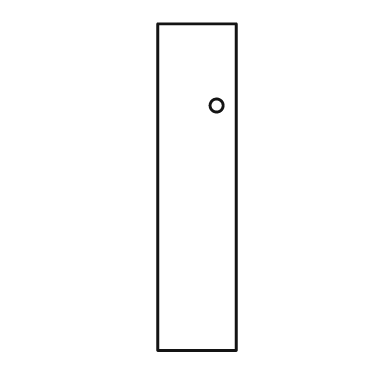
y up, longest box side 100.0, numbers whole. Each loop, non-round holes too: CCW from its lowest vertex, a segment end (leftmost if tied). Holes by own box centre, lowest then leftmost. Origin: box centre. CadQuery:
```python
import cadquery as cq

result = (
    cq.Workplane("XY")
    .moveTo(-12.0, -50.0)
    .lineTo(12.0, -50.0)
    .lineTo(12.0, 50.0)
    .lineTo(-12.0, 50.0)
    .close()
    .moveTo(6.0, 25.0)
    .circle(2.0)
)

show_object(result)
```